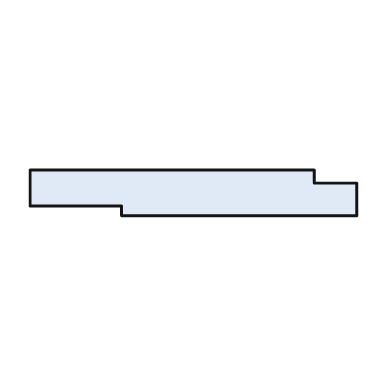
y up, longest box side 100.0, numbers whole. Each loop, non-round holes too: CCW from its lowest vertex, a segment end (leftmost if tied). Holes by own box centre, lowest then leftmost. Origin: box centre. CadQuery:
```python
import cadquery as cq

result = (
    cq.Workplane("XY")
    .moveTo(-22.0, -7.0)
    .lineTo(50.0, -7.0)
    .lineTo(50.0, 3.0)
    .lineTo(37.0, 3.0)
    .lineTo(37.0, 7.0)
    .lineTo(-50.0, 7.0)
    .lineTo(-50.0, -4.0)
    .lineTo(-22.0, -4.0)
    .close()
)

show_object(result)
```